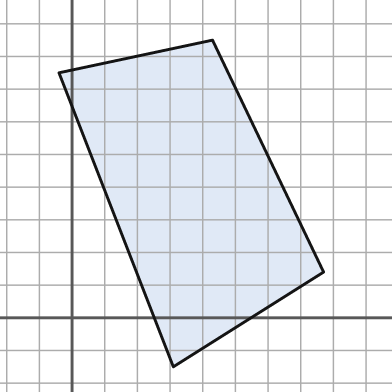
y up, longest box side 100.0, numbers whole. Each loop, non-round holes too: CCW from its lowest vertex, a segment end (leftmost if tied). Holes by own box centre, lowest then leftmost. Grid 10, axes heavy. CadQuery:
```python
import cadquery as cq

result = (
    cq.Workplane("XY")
    .moveTo(31.0, -15.0)
    .lineTo(77.0, 14.0)
    .lineTo(43.0, 85.0)
    .lineTo(-4.0, 75.0)
    .close()
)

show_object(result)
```